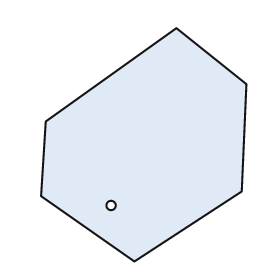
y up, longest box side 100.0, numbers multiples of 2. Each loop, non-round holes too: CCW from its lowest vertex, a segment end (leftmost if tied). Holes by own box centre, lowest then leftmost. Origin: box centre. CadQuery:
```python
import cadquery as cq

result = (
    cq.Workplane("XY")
    .moveTo(-4.0, -50.0)
    .lineTo(42.0, -20.0)
    .lineTo(44.0, 26.0)
    .lineTo(14.0, 50.0)
    .lineTo(-42.0, 10.0)
    .lineTo(-44.0, -22.0)
    .close()
    .moveTo(-14.0, -26.0)
    .circle(2.0)
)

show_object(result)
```